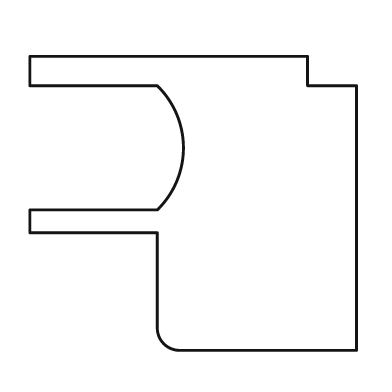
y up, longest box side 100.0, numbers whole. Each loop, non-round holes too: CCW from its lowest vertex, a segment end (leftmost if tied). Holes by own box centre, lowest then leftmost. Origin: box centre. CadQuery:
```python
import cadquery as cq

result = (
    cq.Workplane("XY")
    .moveTo(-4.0, -45.0)
    .lineTo(50.0, -45.0)
    .lineTo(50.0, 36.0)
    .lineTo(35.0, 36.0)
    .lineTo(35.0, 45.0)
    .lineTo(-50.0, 45.0)
    .lineTo(-50.0, 36.0)
    .lineTo(-11.0, 36.0)
    .threePointArc((-3.0, 17.0), (-11.0, -2.0))
    .lineTo(-50.0, -2.0)
    .lineTo(-50.0, -9.0)
    .lineTo(-11.0, -9.0)
    .lineTo(-11.0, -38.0)
    .threePointArc((-9.0, -43.0), (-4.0, -45.0))
    .close()
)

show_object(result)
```